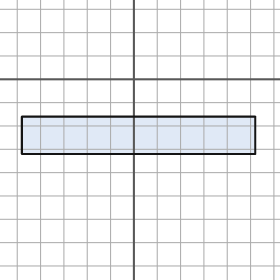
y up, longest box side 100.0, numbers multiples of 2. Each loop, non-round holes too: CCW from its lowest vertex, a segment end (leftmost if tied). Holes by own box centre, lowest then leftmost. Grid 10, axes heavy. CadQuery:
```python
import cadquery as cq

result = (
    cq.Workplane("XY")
    .moveTo(-48.0, -32.0)
    .lineTo(52.0, -32.0)
    .lineTo(52.0, -16.0)
    .lineTo(-48.0, -16.0)
    .close()
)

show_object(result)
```